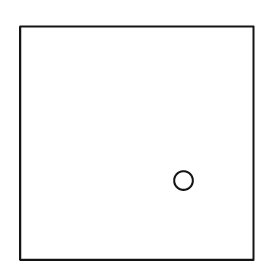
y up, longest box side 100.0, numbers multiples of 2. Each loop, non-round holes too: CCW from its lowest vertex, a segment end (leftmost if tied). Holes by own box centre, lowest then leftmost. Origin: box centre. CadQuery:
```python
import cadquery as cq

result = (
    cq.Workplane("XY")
    .moveTo(-50.0, -50.0)
    .lineTo(50.0, -50.0)
    .lineTo(50.0, 50.0)
    .lineTo(-50.0, 50.0)
    .close()
    .moveTo(20.0, -16.0)
    .circle(4.0)
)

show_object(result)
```